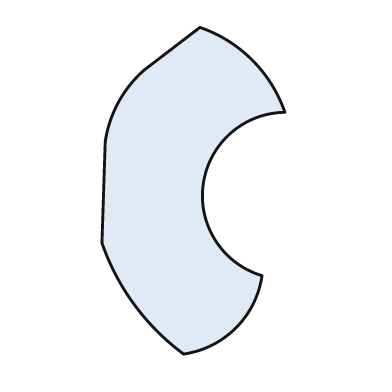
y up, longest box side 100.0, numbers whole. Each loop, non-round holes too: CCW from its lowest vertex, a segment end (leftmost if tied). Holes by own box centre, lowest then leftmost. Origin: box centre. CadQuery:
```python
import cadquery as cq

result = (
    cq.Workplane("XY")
    .moveTo(-3.0, -50.0)
    .threePointArc((13.0, -42.0), (21.0, -26.0))
    .threePointArc((3.0, 2.0), (28.0, 24.0))
    .threePointArc((18.0, 40.0), (2.0, 50.0))
    .lineTo(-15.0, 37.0)
    .threePointArc((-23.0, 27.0), (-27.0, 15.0))
    .lineTo(-28.0, -16.0)
    .threePointArc((-18.0, -35.0), (-3.0, -50.0))
    .close()
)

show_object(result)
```